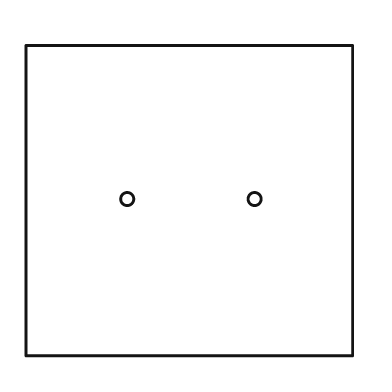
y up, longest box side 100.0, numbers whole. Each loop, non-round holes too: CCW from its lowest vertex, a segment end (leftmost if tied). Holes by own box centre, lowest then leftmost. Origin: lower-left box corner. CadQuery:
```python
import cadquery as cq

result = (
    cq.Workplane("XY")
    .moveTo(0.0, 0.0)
    .lineTo(100.0, 0.0)
    .lineTo(100.0, 95.0)
    .lineTo(0.0, 95.0)
    .close()
    .moveTo(31.0, 48.0)
    .circle(2.0)
    .moveTo(70.0, 48.0)
    .circle(2.0)
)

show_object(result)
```